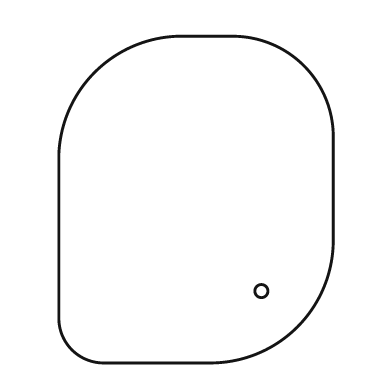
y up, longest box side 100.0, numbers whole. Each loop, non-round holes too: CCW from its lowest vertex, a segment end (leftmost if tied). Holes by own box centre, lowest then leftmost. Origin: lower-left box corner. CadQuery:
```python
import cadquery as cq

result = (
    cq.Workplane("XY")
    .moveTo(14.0, 0.0)
    .lineTo(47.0, 0.0)
    .threePointArc((73.0, 11.0), (84.0, 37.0))
    .lineTo(84.0, 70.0)
    .threePointArc((75.0, 91.0), (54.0, 100.0))
    .lineTo(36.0, 100.0)
    .threePointArc((11.0, 89.0), (0.0, 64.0))
    .lineTo(0.0, 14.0)
    .threePointArc((4.0, 4.0), (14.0, 0.0))
    .close()
    .moveTo(62.0, 22.0)
    .circle(2.0)
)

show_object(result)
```